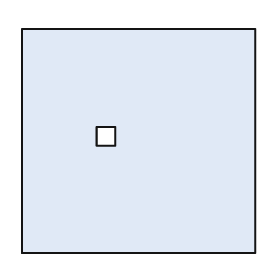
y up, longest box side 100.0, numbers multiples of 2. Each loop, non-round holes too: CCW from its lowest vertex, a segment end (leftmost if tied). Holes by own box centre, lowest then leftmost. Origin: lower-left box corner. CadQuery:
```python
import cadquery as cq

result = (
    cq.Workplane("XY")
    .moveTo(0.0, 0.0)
    .lineTo(100.0, 0.0)
    .lineTo(100.0, 96.0)
    .lineTo(0.0, 96.0)
    .close()
    .moveTo(32.0, 46.0)
    .lineTo(40.0, 46.0)
    .lineTo(40.0, 54.0)
    .lineTo(32.0, 54.0)
    .close()
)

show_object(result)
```